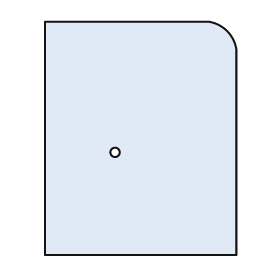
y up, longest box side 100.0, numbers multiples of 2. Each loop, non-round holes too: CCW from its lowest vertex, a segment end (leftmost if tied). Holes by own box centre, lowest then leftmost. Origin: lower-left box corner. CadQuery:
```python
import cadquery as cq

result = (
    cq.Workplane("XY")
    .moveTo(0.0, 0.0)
    .lineTo(82.0, 0.0)
    .lineTo(82.0, 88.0)
    .threePointArc((78.0, 96.0), (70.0, 100.0))
    .lineTo(0.0, 100.0)
    .close()
    .moveTo(30.0, 44.0)
    .circle(2.0)
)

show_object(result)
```